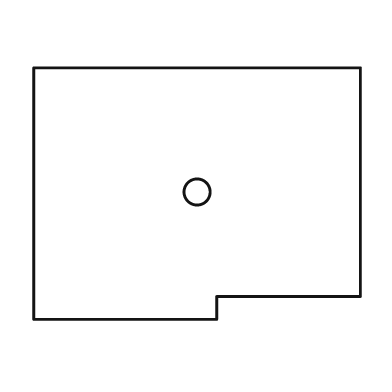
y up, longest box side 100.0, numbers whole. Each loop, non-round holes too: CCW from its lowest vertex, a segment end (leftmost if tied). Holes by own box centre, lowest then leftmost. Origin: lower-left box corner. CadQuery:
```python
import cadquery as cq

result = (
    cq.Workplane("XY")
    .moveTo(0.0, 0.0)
    .lineTo(56.0, 0.0)
    .lineTo(56.0, 7.0)
    .lineTo(100.0, 7.0)
    .lineTo(100.0, 77.0)
    .lineTo(0.0, 77.0)
    .close()
    .moveTo(50.0, 39.0)
    .circle(4.0)
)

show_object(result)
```